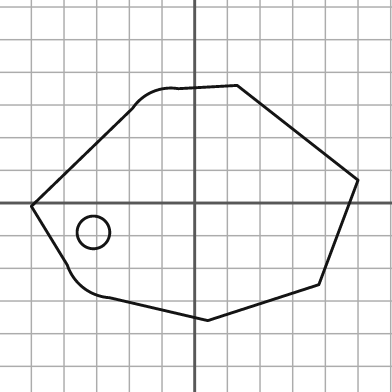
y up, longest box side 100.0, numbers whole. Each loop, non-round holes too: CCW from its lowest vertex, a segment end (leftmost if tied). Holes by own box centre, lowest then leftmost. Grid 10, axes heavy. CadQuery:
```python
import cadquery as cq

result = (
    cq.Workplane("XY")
    .moveTo(4.0, -36.0)
    .lineTo(38.0, -25.0)
    .lineTo(50.0, 7.0)
    .lineTo(13.0, 36.0)
    .lineTo(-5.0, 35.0)
    .threePointArc((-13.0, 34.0), (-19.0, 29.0))
    .lineTo(-50.0, -1.0)
    .lineTo(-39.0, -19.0)
    .threePointArc((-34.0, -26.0), (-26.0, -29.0))
    .close()
    .moveTo(-31.0, -9.0)
    .circle(5.0)
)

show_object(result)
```